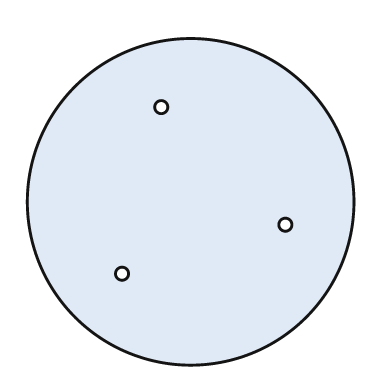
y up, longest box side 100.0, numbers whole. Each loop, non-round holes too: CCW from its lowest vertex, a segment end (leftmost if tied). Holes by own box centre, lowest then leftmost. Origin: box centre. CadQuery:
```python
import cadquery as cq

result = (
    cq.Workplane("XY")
    .moveTo(0.0, 0.0)
    .circle(50.0)
    .moveTo(-21.0, -22.0)
    .circle(2.0)
    .moveTo(29.0, -7.0)
    .circle(2.0)
    .moveTo(-9.0, 29.0)
    .circle(2.0)
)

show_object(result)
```